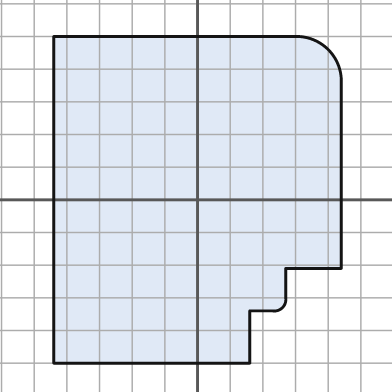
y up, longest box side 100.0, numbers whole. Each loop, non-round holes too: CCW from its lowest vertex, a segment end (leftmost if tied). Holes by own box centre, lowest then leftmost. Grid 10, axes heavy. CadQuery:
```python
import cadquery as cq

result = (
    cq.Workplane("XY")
    .moveTo(-44.0, -50.0)
    .lineTo(16.0, -50.0)
    .lineTo(16.0, -34.0)
    .lineTo(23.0, -34.0)
    .threePointArc((26.0, -33.0), (27.0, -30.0))
    .lineTo(27.0, -21.0)
    .lineTo(44.0, -21.0)
    .lineTo(44.0, 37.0)
    .threePointArc((40.0, 46.0), (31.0, 50.0))
    .lineTo(-44.0, 50.0)
    .close()
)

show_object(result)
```